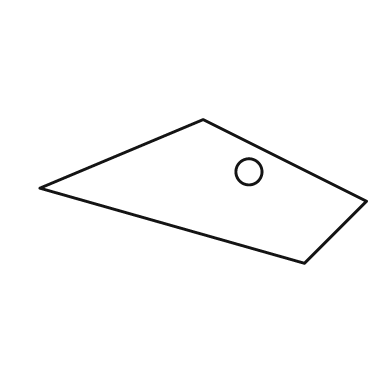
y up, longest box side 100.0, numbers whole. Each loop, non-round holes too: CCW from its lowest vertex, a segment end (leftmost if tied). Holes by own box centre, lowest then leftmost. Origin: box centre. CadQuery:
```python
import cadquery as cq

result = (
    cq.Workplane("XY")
    .moveTo(31.0, -22.0)
    .lineTo(50.0, -3.0)
    .lineTo(0.0, 22.0)
    .lineTo(-50.0, 1.0)
    .close()
    .moveTo(14.0, 6.0)
    .circle(4.0)
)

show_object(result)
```